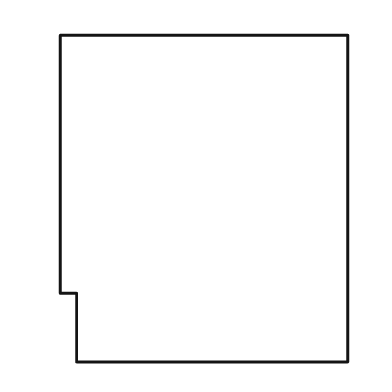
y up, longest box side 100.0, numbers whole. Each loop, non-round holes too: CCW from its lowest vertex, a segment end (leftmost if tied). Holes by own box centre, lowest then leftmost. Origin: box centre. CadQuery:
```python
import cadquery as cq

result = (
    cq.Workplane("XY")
    .moveTo(-39.0, -50.0)
    .lineTo(44.0, -50.0)
    .lineTo(44.0, 50.0)
    .lineTo(-44.0, 50.0)
    .lineTo(-44.0, -29.0)
    .lineTo(-39.0, -29.0)
    .close()
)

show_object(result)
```